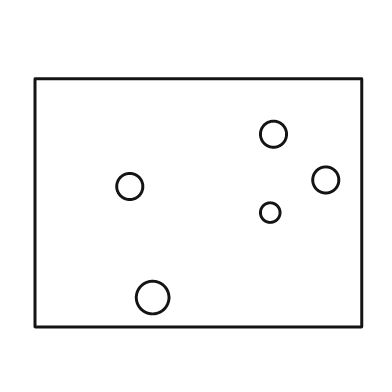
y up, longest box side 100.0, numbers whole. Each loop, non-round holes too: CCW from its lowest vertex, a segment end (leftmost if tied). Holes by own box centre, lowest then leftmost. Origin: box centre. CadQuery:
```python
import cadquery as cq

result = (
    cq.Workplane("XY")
    .moveTo(-50.0, -38.0)
    .lineTo(50.0, -38.0)
    .lineTo(50.0, 38.0)
    .lineTo(-50.0, 38.0)
    .close()
    .moveTo(-14.0, -29.0)
    .circle(5.0)
    .moveTo(22.0, -3.0)
    .circle(3.0)
    .moveTo(-21.0, 5.0)
    .circle(4.0)
    .moveTo(39.0, 7.0)
    .circle(4.0)
    .moveTo(23.0, 21.0)
    .circle(4.0)
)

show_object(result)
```